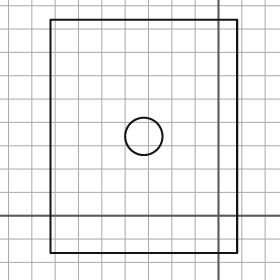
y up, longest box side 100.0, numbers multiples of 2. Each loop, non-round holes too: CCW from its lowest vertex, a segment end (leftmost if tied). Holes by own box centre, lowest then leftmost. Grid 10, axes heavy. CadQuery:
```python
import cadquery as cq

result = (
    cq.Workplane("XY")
    .moveTo(-72.0, -16.0)
    .lineTo(8.0, -16.0)
    .lineTo(8.0, 84.0)
    .lineTo(-72.0, 84.0)
    .close()
    .moveTo(-32.0, 34.0)
    .circle(8.0)
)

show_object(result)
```